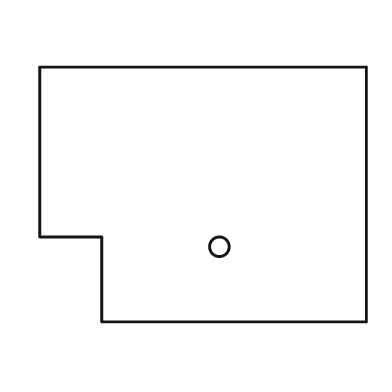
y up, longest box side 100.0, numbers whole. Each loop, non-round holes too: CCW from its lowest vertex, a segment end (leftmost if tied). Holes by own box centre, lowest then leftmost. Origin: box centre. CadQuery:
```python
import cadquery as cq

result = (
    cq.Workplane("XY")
    .moveTo(-31.0, -39.0)
    .lineTo(50.0, -39.0)
    .lineTo(50.0, 39.0)
    .lineTo(-50.0, 39.0)
    .lineTo(-50.0, -13.0)
    .lineTo(-31.0, -13.0)
    .close()
    .moveTo(5.0, -16.0)
    .circle(3.0)
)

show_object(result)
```